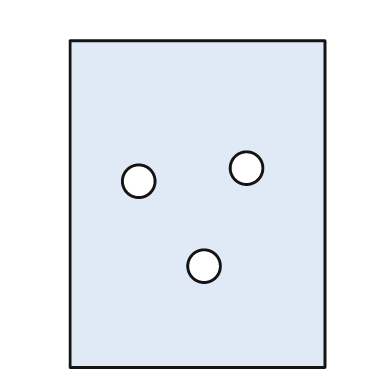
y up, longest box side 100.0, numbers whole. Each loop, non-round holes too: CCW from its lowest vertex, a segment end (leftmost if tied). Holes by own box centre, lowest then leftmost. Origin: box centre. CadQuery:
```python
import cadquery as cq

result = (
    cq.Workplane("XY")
    .moveTo(-39.0, -50.0)
    .lineTo(39.0, -50.0)
    .lineTo(39.0, 50.0)
    .lineTo(-39.0, 50.0)
    .close()
    .moveTo(2.0, -19.0)
    .circle(5.0)
    .moveTo(-18.0, 7.0)
    .circle(5.0)
    .moveTo(15.0, 11.0)
    .circle(5.0)
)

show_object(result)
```